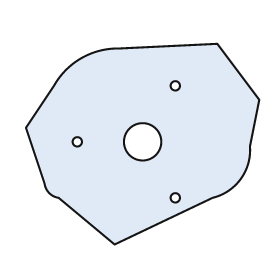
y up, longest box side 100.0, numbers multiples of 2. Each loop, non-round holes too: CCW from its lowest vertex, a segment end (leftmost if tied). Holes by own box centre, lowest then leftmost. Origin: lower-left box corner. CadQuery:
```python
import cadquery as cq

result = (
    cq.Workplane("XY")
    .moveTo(38.0, 0.0)
    .lineTo(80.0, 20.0)
    .threePointArc((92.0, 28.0), (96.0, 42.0))
    .lineTo(100.0, 62.0)
    .lineTo(82.0, 86.0)
    .lineTo(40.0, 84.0)
    .threePointArc((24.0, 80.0), (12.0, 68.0))
    .lineTo(0.0, 50.0)
    .lineTo(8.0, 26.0)
    .threePointArc((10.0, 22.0), (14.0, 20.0))
    .close()
    .moveTo(64.0, 20.0)
    .circle(2.0)
    .moveTo(22.0, 44.0)
    .circle(2.0)
    .moveTo(50.0, 44.0)
    .circle(8.0)
    .moveTo(64.0, 68.0)
    .circle(2.0)
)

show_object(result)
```